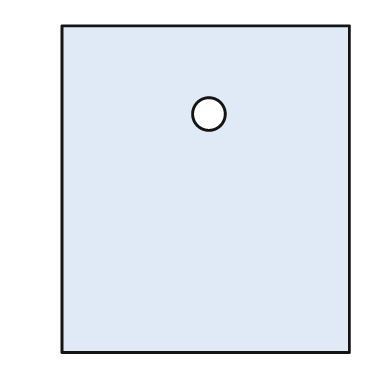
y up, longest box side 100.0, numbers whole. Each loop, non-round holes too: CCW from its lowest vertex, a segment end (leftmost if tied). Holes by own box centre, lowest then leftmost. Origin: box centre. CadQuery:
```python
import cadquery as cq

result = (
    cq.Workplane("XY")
    .moveTo(-44.0, -50.0)
    .lineTo(44.0, -50.0)
    .lineTo(44.0, 50.0)
    .lineTo(-44.0, 50.0)
    .close()
    .moveTo(1.0, 23.0)
    .circle(5.0)
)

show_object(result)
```